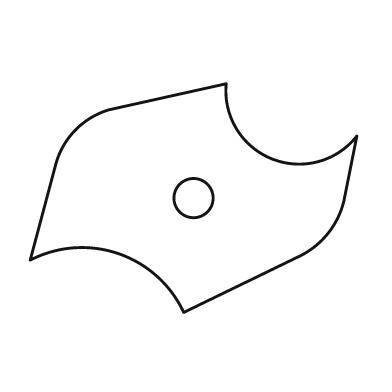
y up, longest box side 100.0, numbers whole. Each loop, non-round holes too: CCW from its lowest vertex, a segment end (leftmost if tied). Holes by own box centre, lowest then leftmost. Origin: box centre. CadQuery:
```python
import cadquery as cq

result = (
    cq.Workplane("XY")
    .moveTo(-3.0, -35.0)
    .lineTo(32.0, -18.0)
    .threePointArc((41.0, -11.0), (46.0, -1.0))
    .lineTo(50.0, 19.0)
    .threePointArc((24.0, 12.0), (10.0, 35.0))
    .lineTo(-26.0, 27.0)
    .threePointArc((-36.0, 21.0), (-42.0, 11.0))
    .lineTo(-50.0, -19.0)
    .threePointArc((-23.0, -17.0), (-3.0, -35.0))
    .close()
    .moveTo(0.0, 0.0)
    .circle(6.0)
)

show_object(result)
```